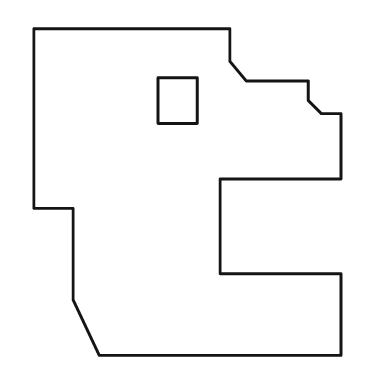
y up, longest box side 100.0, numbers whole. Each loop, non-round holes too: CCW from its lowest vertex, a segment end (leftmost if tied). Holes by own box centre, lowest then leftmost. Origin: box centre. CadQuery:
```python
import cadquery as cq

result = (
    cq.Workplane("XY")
    .moveTo(-27.0, -50.0)
    .lineTo(47.0, -50.0)
    .lineTo(47.0, -25.0)
    .lineTo(10.0, -25.0)
    .lineTo(10.0, 4.0)
    .lineTo(47.0, 4.0)
    .lineTo(47.0, 24.0)
    .lineTo(41.0, 24.0)
    .lineTo(37.0, 28.0)
    .lineTo(37.0, 34.0)
    .lineTo(18.0, 34.0)
    .lineTo(13.0, 40.0)
    .lineTo(13.0, 50.0)
    .lineTo(-47.0, 50.0)
    .lineTo(-47.0, -5.0)
    .lineTo(-35.0, -5.0)
    .lineTo(-35.0, -33.0)
    .close()
    .moveTo(-9.0, 21.0)
    .lineTo(3.0, 21.0)
    .lineTo(3.0, 35.0)
    .lineTo(-9.0, 35.0)
    .close()
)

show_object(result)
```